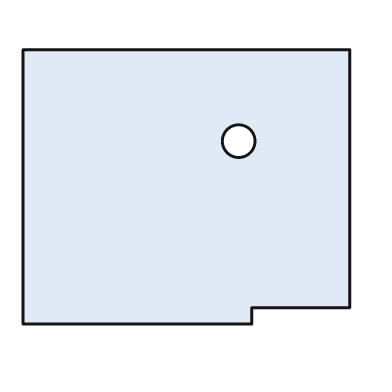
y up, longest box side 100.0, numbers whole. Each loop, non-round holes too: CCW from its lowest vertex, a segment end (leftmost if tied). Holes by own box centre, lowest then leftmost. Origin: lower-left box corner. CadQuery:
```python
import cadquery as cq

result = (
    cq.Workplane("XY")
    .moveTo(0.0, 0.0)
    .lineTo(70.0, 0.0)
    .lineTo(70.0, 5.0)
    .lineTo(100.0, 5.0)
    .lineTo(100.0, 84.0)
    .lineTo(0.0, 84.0)
    .close()
    .moveTo(66.0, 56.0)
    .circle(5.0)
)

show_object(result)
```